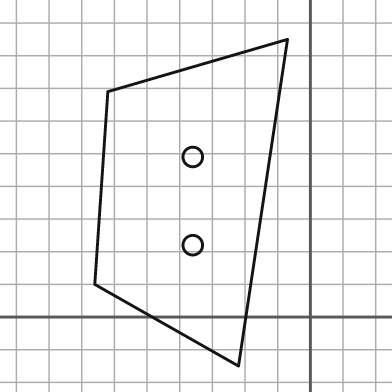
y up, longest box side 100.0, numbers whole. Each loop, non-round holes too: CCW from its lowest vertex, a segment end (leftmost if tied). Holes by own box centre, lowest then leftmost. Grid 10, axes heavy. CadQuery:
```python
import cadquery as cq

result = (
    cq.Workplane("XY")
    .moveTo(-22.0, -15.0)
    .lineTo(-7.0, 85.0)
    .lineTo(-62.0, 69.0)
    .lineTo(-66.0, 10.0)
    .close()
    .moveTo(-36.0, 22.0)
    .circle(3.0)
    .moveTo(-36.0, 49.0)
    .circle(3.0)
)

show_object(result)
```